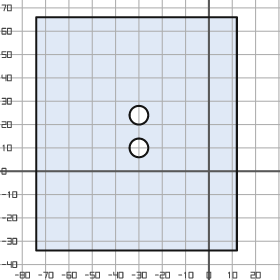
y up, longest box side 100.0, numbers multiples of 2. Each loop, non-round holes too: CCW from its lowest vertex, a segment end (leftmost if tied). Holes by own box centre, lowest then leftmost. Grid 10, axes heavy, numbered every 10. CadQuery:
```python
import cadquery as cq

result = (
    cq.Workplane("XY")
    .moveTo(-74.0, -34.0)
    .lineTo(12.0, -34.0)
    .lineTo(12.0, 66.0)
    .lineTo(-74.0, 66.0)
    .close()
    .moveTo(-30.0, 10.0)
    .circle(4.0)
    .moveTo(-30.0, 24.0)
    .circle(4.0)
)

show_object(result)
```